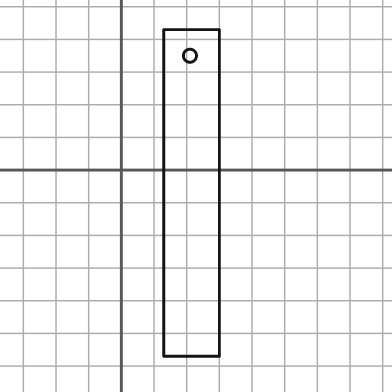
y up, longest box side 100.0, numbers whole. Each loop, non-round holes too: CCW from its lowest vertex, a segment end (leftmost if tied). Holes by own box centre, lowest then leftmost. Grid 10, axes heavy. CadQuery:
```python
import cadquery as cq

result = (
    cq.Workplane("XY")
    .moveTo(13.0, -57.0)
    .lineTo(30.0, -57.0)
    .lineTo(30.0, 43.0)
    .lineTo(13.0, 43.0)
    .close()
    .moveTo(21.0, 35.0)
    .circle(2.0)
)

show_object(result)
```